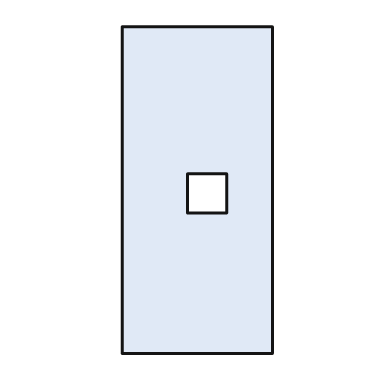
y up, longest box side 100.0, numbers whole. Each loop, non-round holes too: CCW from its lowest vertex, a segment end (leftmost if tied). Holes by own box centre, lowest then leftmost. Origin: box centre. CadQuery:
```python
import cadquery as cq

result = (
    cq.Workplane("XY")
    .moveTo(-23.0, -50.0)
    .lineTo(23.0, -50.0)
    .lineTo(23.0, 50.0)
    .lineTo(-23.0, 50.0)
    .close()
    .moveTo(-3.0, -7.0)
    .lineTo(9.0, -7.0)
    .lineTo(9.0, 5.0)
    .lineTo(-3.0, 5.0)
    .close()
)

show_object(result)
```